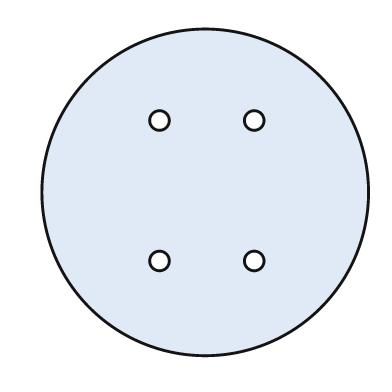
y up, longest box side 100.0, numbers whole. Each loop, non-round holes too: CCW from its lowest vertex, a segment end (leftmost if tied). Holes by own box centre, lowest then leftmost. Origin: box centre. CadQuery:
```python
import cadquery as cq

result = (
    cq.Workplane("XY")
    .moveTo(0.0, 0.0)
    .circle(50.0)
    .moveTo(-14.0, -21.0)
    .circle(3.0)
    .moveTo(15.0, -21.0)
    .circle(3.0)
    .moveTo(-14.0, 22.0)
    .circle(3.0)
    .moveTo(15.0, 22.0)
    .circle(3.0)
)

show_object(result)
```